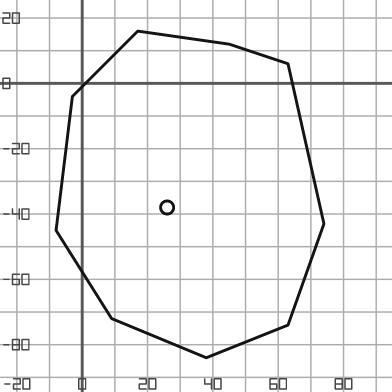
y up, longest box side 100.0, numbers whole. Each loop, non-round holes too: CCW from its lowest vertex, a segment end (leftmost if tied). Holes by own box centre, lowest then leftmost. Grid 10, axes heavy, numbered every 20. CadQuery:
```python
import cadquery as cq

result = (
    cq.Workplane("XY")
    .moveTo(38.0, -84.0)
    .lineTo(63.0, -74.0)
    .lineTo(74.0, -43.0)
    .lineTo(63.0, 6.0)
    .lineTo(45.0, 12.0)
    .lineTo(17.0, 16.0)
    .lineTo(-3.0, -4.0)
    .lineTo(-8.0, -45.0)
    .lineTo(9.0, -72.0)
    .close()
    .moveTo(26.0, -38.0)
    .circle(2.0)
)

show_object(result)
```